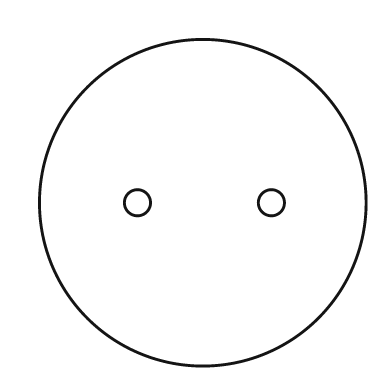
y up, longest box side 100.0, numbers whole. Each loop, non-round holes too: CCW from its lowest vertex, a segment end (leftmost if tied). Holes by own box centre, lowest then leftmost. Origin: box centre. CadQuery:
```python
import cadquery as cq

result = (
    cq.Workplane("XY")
    .moveTo(0.0, 0.0)
    .circle(50.0)
    .moveTo(-20.0, 0.0)
    .circle(4.0)
    .moveTo(21.0, 0.0)
    .circle(4.0)
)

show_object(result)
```